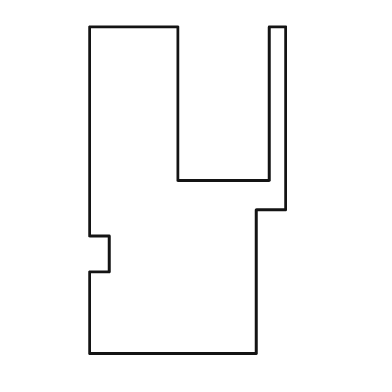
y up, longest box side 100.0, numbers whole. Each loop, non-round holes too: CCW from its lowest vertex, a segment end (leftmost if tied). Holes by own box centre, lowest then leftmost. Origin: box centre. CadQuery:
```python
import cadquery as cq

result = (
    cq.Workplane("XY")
    .moveTo(-30.0, -50.0)
    .lineTo(21.0, -50.0)
    .lineTo(21.0, -6.0)
    .lineTo(30.0, -6.0)
    .lineTo(30.0, 50.0)
    .lineTo(25.0, 50.0)
    .lineTo(25.0, 3.0)
    .lineTo(-3.0, 3.0)
    .lineTo(-3.0, 50.0)
    .lineTo(-30.0, 50.0)
    .lineTo(-30.0, -14.0)
    .lineTo(-24.0, -14.0)
    .lineTo(-24.0, -25.0)
    .lineTo(-30.0, -25.0)
    .close()
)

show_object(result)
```